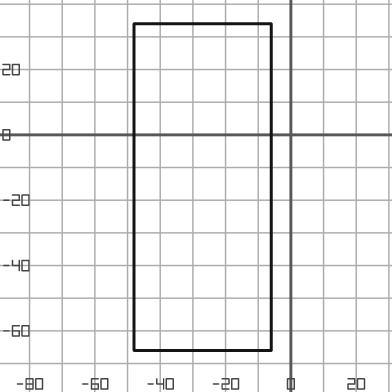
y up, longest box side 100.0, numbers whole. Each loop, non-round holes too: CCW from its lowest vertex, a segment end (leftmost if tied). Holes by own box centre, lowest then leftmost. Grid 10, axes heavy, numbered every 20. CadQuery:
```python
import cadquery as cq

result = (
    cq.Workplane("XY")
    .moveTo(-48.0, -66.0)
    .lineTo(-6.0, -66.0)
    .lineTo(-6.0, 34.0)
    .lineTo(-48.0, 34.0)
    .close()
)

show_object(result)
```